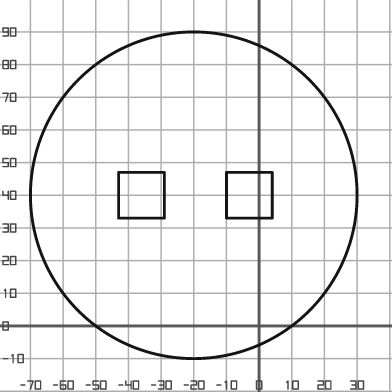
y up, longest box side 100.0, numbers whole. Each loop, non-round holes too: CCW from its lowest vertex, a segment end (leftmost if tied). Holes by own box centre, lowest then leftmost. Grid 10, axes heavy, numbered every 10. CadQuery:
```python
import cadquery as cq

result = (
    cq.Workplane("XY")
    .moveTo(-20.0, 40.0)
    .circle(50.0)
    .moveTo(-43.0, 33.0)
    .lineTo(-29.0, 33.0)
    .lineTo(-29.0, 47.0)
    .lineTo(-43.0, 47.0)
    .close()
    .moveTo(-10.0, 33.0)
    .lineTo(4.0, 33.0)
    .lineTo(4.0, 47.0)
    .lineTo(-10.0, 47.0)
    .close()
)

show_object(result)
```